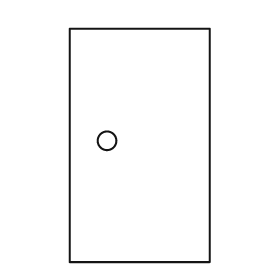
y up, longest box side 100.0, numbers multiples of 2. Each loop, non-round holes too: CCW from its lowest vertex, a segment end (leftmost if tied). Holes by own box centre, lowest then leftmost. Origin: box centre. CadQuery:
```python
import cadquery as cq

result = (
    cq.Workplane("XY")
    .moveTo(-30.0, -50.0)
    .lineTo(30.0, -50.0)
    .lineTo(30.0, 50.0)
    .lineTo(-30.0, 50.0)
    .close()
    .moveTo(-14.0, 2.0)
    .circle(4.0)
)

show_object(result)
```